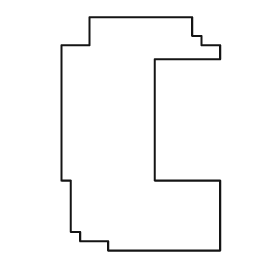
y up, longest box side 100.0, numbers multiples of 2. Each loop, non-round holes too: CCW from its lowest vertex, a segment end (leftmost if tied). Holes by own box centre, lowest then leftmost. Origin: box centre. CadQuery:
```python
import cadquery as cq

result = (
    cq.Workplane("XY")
    .moveTo(-14.0, -50.0)
    .lineTo(34.0, -50.0)
    .lineTo(34.0, -20.0)
    .lineTo(6.0, -20.0)
    .lineTo(6.0, 32.0)
    .lineTo(34.0, 32.0)
    .lineTo(34.0, 38.0)
    .lineTo(26.0, 38.0)
    .lineTo(26.0, 42.0)
    .lineTo(22.0, 42.0)
    .lineTo(22.0, 50.0)
    .lineTo(-22.0, 50.0)
    .lineTo(-22.0, 38.0)
    .lineTo(-34.0, 38.0)
    .lineTo(-34.0, -20.0)
    .lineTo(-30.0, -20.0)
    .lineTo(-30.0, -42.0)
    .lineTo(-26.0, -42.0)
    .lineTo(-26.0, -46.0)
    .lineTo(-14.0, -46.0)
    .close()
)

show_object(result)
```